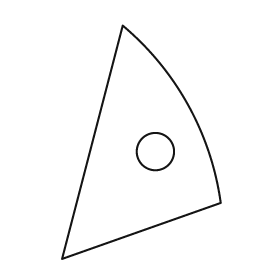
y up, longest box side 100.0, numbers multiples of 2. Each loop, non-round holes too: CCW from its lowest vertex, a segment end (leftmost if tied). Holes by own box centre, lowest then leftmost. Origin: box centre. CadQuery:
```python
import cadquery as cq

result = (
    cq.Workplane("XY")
    .moveTo(-34.0, -50.0)
    .lineTo(34.0, -26.0)
    .threePointArc((20.0, 16.0), (-8.0, 50.0))
    .close()
    .moveTo(6.0, -4.0)
    .circle(8.0)
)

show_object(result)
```